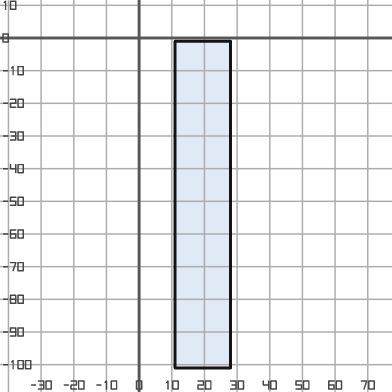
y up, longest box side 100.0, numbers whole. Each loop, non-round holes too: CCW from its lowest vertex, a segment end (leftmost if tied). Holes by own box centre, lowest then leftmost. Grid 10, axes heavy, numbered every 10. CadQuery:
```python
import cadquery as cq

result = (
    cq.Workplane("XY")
    .moveTo(11.0, -101.0)
    .lineTo(28.0, -101.0)
    .lineTo(28.0, -1.0)
    .lineTo(11.0, -1.0)
    .close()
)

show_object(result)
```